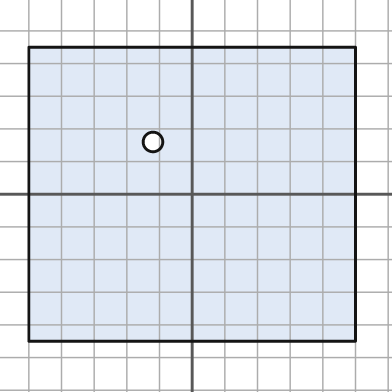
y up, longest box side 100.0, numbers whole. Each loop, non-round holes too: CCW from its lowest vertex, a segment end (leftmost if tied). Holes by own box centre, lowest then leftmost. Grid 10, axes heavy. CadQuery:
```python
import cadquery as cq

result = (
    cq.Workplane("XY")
    .moveTo(-50.0, -45.0)
    .lineTo(50.0, -45.0)
    .lineTo(50.0, 45.0)
    .lineTo(-50.0, 45.0)
    .close()
    .moveTo(-12.0, 16.0)
    .circle(3.0)
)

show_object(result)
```